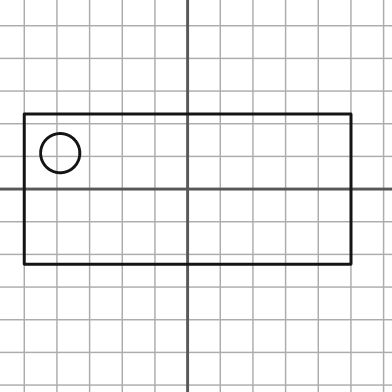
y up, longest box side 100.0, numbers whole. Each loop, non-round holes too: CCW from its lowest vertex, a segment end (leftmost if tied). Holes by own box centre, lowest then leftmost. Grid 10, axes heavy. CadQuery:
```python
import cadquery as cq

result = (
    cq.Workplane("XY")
    .moveTo(-50.0, -23.0)
    .lineTo(50.0, -23.0)
    .lineTo(50.0, 23.0)
    .lineTo(-50.0, 23.0)
    .close()
    .moveTo(-39.0, 11.0)
    .circle(6.0)
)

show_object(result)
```